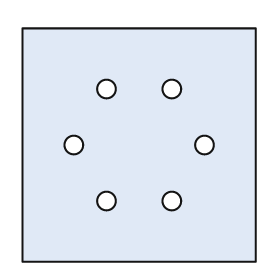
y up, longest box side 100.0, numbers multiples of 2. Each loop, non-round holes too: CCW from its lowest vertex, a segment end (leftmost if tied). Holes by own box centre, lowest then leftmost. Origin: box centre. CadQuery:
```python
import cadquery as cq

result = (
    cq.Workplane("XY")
    .moveTo(-50.0, -50.0)
    .lineTo(50.0, -50.0)
    .lineTo(50.0, 50.0)
    .lineTo(-50.0, 50.0)
    .close()
    .moveTo(-14.0, -24.0)
    .circle(4.0)
    .moveTo(14.0, -24.0)
    .circle(4.0)
    .moveTo(-28.0, 0.0)
    .circle(4.0)
    .moveTo(28.0, 0.0)
    .circle(4.0)
    .moveTo(-14.0, 24.0)
    .circle(4.0)
    .moveTo(14.0, 24.0)
    .circle(4.0)
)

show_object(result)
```